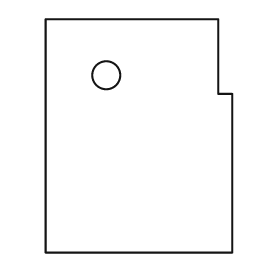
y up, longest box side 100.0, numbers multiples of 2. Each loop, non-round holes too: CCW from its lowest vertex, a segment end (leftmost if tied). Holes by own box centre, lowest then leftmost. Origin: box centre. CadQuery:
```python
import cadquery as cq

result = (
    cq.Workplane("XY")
    .moveTo(-40.0, -50.0)
    .lineTo(40.0, -50.0)
    .lineTo(40.0, 18.0)
    .lineTo(34.0, 18.0)
    .lineTo(34.0, 50.0)
    .lineTo(-40.0, 50.0)
    .close()
    .moveTo(-14.0, 26.0)
    .circle(6.0)
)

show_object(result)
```